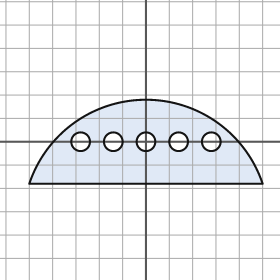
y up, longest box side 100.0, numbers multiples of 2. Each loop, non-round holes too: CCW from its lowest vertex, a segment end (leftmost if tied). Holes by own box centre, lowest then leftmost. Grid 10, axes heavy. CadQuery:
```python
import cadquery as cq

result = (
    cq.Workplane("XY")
    .moveTo(-50.0, -18.0)
    .lineTo(50.0, -18.0)
    .threePointArc((0.0, 18.0), (-50.0, -18.0))
    .close()
    .moveTo(-28.0, 0.0)
    .circle(4.0)
    .moveTo(-14.0, 0.0)
    .circle(4.0)
    .moveTo(0.0, 0.0)
    .circle(4.0)
    .moveTo(14.0, 0.0)
    .circle(4.0)
    .moveTo(28.0, 0.0)
    .circle(4.0)
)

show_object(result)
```